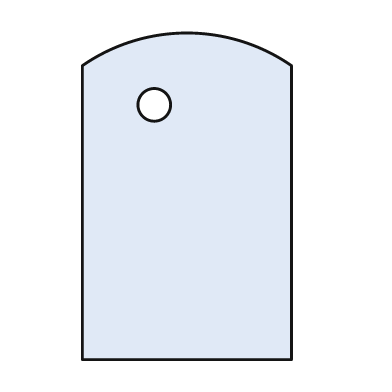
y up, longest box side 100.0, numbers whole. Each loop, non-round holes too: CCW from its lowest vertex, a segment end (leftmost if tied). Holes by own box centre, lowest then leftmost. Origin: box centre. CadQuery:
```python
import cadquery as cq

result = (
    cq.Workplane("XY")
    .moveTo(-32.0, -50.0)
    .lineTo(32.0, -50.0)
    .lineTo(32.0, 40.0)
    .threePointArc((0.0, 50.0), (-32.0, 40.0))
    .close()
    .moveTo(-10.0, 28.0)
    .circle(5.0)
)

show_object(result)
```